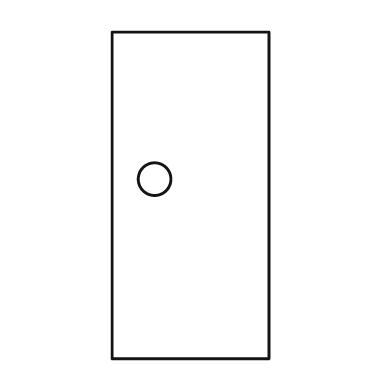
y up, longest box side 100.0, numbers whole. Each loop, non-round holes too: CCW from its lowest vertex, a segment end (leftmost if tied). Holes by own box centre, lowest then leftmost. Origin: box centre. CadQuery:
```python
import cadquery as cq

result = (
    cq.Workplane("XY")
    .moveTo(-24.0, -50.0)
    .lineTo(24.0, -50.0)
    .lineTo(24.0, 50.0)
    .lineTo(-24.0, 50.0)
    .close()
    .moveTo(-11.0, 5.0)
    .circle(5.0)
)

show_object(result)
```